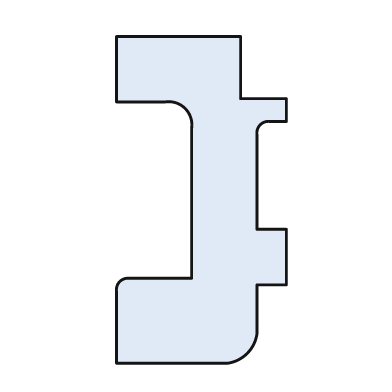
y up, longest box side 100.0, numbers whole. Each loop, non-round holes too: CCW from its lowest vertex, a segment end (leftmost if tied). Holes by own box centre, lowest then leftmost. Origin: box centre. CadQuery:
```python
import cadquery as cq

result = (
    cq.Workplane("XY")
    .moveTo(-26.0, -50.0)
    .lineTo(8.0, -50.0)
    .threePointArc((14.0, -47.0), (17.0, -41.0))
    .lineTo(17.0, -26.0)
    .lineTo(26.0, -26.0)
    .lineTo(26.0, -9.0)
    .lineTo(17.0, -9.0)
    .lineTo(17.0, 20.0)
    .threePointArc((18.0, 23.0), (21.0, 24.0))
    .lineTo(26.0, 24.0)
    .lineTo(26.0, 31.0)
    .lineTo(12.0, 31.0)
    .lineTo(12.0, 50.0)
    .lineTo(-26.0, 50.0)
    .lineTo(-26.0, 30.0)
    .lineTo(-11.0, 30.0)
    .threePointArc((-5.0, 28.0), (-3.0, 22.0))
    .lineTo(-3.0, -24.0)
    .lineTo(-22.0, -24.0)
    .threePointArc((-25.0, -25.0), (-26.0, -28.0))
    .close()
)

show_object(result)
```